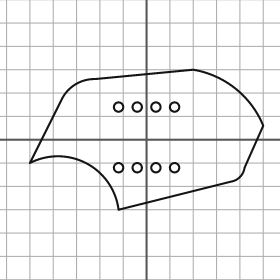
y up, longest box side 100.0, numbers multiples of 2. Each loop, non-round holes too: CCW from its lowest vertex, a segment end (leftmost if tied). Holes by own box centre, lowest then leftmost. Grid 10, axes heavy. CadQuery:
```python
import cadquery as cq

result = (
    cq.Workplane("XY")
    .moveTo(-12.0, -30.0)
    .lineTo(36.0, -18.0)
    .threePointArc((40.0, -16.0), (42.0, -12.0))
    .lineTo(50.0, 6.0)
    .threePointArc((38.0, 22.0), (20.0, 30.0))
    .lineTo(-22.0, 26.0)
    .threePointArc((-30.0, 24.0), (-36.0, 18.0))
    .lineTo(-50.0, -10.0)
    .threePointArc((-26.0, -10.0), (-12.0, -30.0))
    .close()
    .moveTo(-12.0, -12.0)
    .circle(2.0)
    .moveTo(-4.0, -12.0)
    .circle(2.0)
    .moveTo(4.0, -12.0)
    .circle(2.0)
    .moveTo(12.0, -12.0)
    .circle(2.0)
    .moveTo(-12.0, 14.0)
    .circle(2.0)
    .moveTo(-4.0, 14.0)
    .circle(2.0)
    .moveTo(4.0, 14.0)
    .circle(2.0)
    .moveTo(12.0, 14.0)
    .circle(2.0)
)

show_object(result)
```